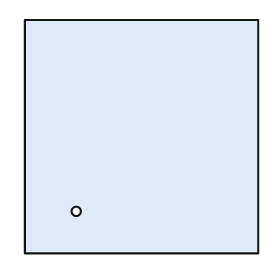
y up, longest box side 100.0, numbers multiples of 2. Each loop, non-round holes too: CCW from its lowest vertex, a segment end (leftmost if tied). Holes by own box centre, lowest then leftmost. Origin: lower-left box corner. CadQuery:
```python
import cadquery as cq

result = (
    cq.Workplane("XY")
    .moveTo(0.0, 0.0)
    .lineTo(100.0, 0.0)
    .lineTo(100.0, 100.0)
    .lineTo(0.0, 100.0)
    .close()
    .moveTo(22.0, 18.0)
    .circle(2.0)
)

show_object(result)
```